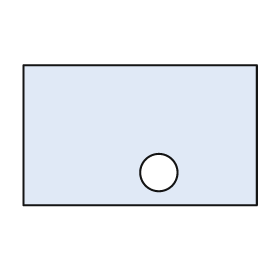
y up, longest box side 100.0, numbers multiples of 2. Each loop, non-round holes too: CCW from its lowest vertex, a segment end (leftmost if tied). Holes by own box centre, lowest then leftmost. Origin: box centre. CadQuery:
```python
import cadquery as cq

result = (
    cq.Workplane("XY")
    .moveTo(-50.0, -30.0)
    .lineTo(50.0, -30.0)
    .lineTo(50.0, 30.0)
    .lineTo(-50.0, 30.0)
    .close()
    .moveTo(8.0, -16.0)
    .circle(8.0)
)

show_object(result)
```